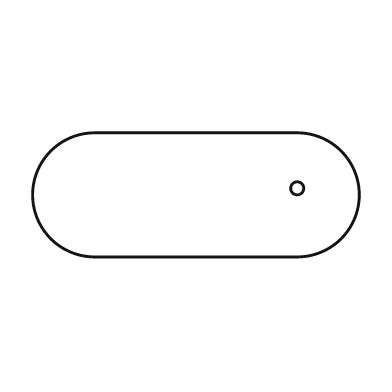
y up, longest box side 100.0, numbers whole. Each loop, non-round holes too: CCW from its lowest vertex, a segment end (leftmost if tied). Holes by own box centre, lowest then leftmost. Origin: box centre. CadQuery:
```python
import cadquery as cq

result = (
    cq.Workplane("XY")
    .moveTo(-31.0, -19.0)
    .lineTo(31.0, -19.0)
    .threePointArc((50.0, 0.0), (31.0, 19.0))
    .lineTo(-31.0, 19.0)
    .threePointArc((-50.0, 0.0), (-31.0, -19.0))
    .close()
    .moveTo(31.0, 2.0)
    .circle(2.0)
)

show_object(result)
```